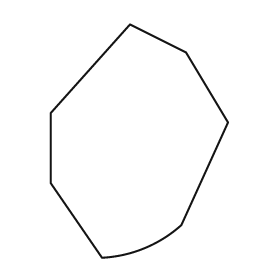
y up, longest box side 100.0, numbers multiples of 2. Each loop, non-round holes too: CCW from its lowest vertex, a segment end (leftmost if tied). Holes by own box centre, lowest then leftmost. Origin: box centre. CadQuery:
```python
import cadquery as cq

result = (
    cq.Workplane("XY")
    .moveTo(-16.0, -50.0)
    .threePointArc((2.0, -46.0), (18.0, -36.0))
    .lineTo(38.0, 8.0)
    .lineTo(20.0, 38.0)
    .lineTo(-4.0, 50.0)
    .lineTo(-38.0, 12.0)
    .lineTo(-38.0, -18.0)
    .close()
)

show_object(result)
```